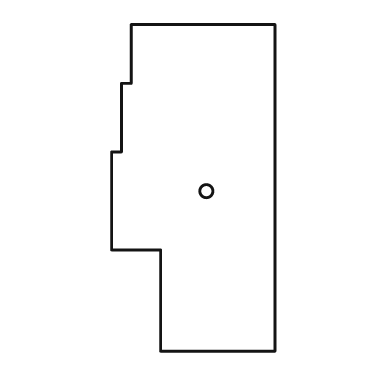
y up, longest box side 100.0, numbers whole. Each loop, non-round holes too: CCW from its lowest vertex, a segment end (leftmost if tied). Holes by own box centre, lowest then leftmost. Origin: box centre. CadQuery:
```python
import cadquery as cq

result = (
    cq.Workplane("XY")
    .moveTo(-10.0, -50.0)
    .lineTo(25.0, -50.0)
    .lineTo(25.0, 50.0)
    .lineTo(-19.0, 50.0)
    .lineTo(-19.0, 32.0)
    .lineTo(-22.0, 32.0)
    .lineTo(-22.0, 11.0)
    .lineTo(-25.0, 11.0)
    .lineTo(-25.0, -19.0)
    .lineTo(-10.0, -19.0)
    .close()
    .moveTo(4.0, -1.0)
    .circle(2.0)
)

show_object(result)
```